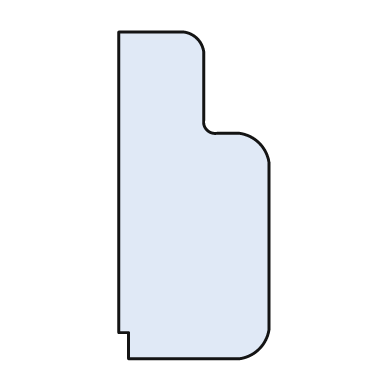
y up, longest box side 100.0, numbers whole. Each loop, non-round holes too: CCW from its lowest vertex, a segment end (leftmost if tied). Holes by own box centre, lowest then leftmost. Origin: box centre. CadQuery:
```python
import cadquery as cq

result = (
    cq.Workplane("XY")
    .moveTo(-20.0, -50.0)
    .lineTo(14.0, -50.0)
    .threePointArc((20.0, -47.0), (23.0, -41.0))
    .lineTo(23.0, 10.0)
    .threePointArc((20.0, 16.0), (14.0, 19.0))
    .lineTo(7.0, 19.0)
    .threePointArc((4.0, 20.0), (3.0, 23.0))
    .lineTo(3.0, 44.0)
    .threePointArc((1.0, 48.0), (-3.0, 50.0))
    .lineTo(-23.0, 50.0)
    .lineTo(-23.0, -42.0)
    .lineTo(-20.0, -42.0)
    .close()
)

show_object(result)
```